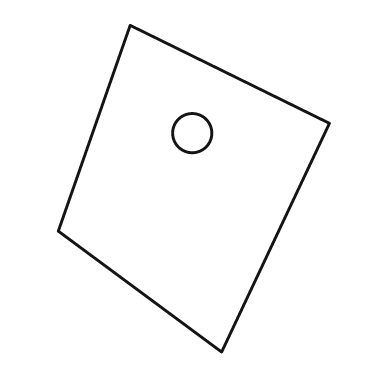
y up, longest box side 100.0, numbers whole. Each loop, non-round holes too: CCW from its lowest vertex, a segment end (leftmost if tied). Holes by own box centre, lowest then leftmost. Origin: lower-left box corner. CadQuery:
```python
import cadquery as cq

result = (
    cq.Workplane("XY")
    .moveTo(50.0, 0.0)
    .lineTo(83.0, 70.0)
    .lineTo(22.0, 100.0)
    .lineTo(0.0, 37.0)
    .close()
    .moveTo(41.0, 67.0)
    .circle(6.0)
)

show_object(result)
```